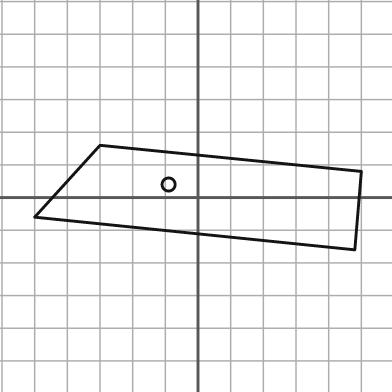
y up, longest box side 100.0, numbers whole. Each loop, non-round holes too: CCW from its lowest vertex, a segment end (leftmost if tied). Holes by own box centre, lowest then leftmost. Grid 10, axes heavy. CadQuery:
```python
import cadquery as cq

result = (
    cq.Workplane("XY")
    .moveTo(48.0, -16.0)
    .lineTo(50.0, 8.0)
    .lineTo(-30.0, 16.0)
    .lineTo(-50.0, -6.0)
    .close()
    .moveTo(-9.0, 4.0)
    .circle(2.0)
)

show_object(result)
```